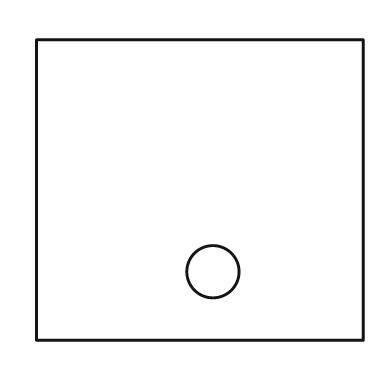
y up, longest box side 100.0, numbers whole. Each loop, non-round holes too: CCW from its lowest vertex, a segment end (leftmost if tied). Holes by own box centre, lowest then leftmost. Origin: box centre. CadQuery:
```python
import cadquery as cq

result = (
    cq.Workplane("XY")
    .moveTo(-50.0, -46.0)
    .lineTo(50.0, -46.0)
    .lineTo(50.0, 46.0)
    .lineTo(-50.0, 46.0)
    .close()
    .moveTo(4.0, -25.0)
    .circle(8.0)
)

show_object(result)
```